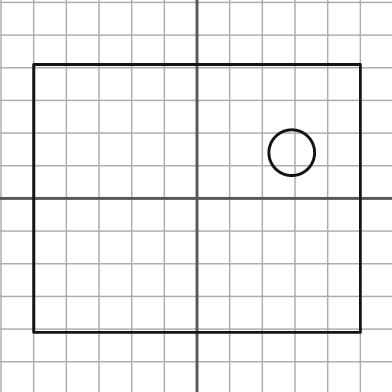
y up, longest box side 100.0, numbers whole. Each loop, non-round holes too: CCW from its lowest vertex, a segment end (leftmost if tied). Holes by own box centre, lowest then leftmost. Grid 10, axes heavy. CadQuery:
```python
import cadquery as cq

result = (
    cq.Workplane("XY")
    .moveTo(-50.0, -41.0)
    .lineTo(50.0, -41.0)
    .lineTo(50.0, 41.0)
    .lineTo(-50.0, 41.0)
    .close()
    .moveTo(29.0, 14.0)
    .circle(7.0)
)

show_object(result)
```